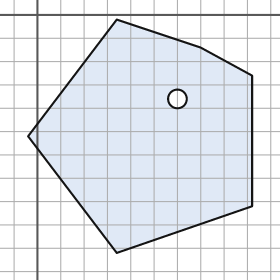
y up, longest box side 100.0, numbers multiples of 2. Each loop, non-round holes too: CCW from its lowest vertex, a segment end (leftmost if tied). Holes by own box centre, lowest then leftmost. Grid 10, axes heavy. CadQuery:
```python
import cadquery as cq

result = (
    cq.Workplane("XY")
    .moveTo(34.0, -102.0)
    .lineTo(92.0, -82.0)
    .lineTo(92.0, -26.0)
    .lineTo(70.0, -14.0)
    .lineTo(34.0, -2.0)
    .lineTo(-4.0, -52.0)
    .close()
    .moveTo(60.0, -36.0)
    .circle(4.0)
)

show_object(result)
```